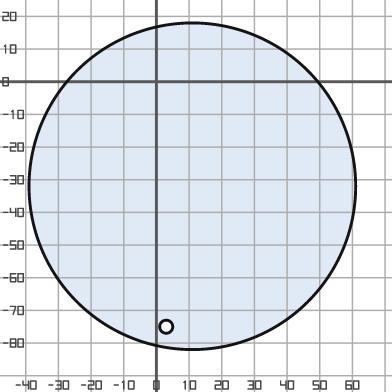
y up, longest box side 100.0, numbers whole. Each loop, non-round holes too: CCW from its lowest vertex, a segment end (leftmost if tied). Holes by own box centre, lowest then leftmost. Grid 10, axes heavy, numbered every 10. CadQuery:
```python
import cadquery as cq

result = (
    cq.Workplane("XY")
    .moveTo(11.0, -32.0)
    .circle(50.0)
    .moveTo(3.0, -75.0)
    .circle(2.0)
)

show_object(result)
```